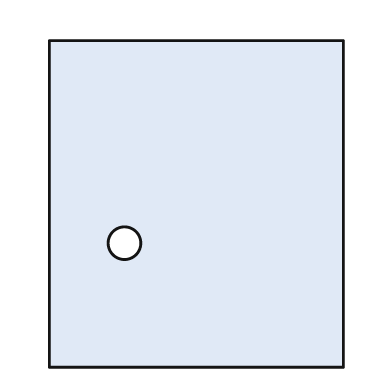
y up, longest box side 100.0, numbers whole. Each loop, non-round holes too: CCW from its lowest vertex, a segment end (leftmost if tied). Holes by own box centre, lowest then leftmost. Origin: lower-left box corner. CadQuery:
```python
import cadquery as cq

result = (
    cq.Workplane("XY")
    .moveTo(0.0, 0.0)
    .lineTo(90.0, 0.0)
    .lineTo(90.0, 100.0)
    .lineTo(0.0, 100.0)
    .close()
    .moveTo(23.0, 38.0)
    .circle(5.0)
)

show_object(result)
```